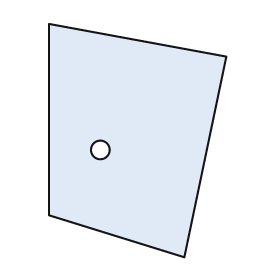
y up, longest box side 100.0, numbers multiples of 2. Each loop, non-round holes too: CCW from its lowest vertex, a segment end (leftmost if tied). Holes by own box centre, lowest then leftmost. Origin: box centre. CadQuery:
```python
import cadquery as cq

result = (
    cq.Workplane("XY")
    .moveTo(20.0, -50.0)
    .lineTo(38.0, 36.0)
    .lineTo(-38.0, 50.0)
    .lineTo(-38.0, -32.0)
    .close()
    .moveTo(-16.0, -4.0)
    .circle(4.0)
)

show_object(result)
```